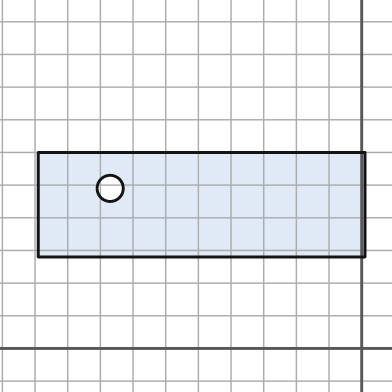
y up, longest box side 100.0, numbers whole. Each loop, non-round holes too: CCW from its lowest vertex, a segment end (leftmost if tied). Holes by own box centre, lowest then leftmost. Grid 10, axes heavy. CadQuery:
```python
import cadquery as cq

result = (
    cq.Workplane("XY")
    .moveTo(-99.0, 28.0)
    .lineTo(1.0, 28.0)
    .lineTo(1.0, 60.0)
    .lineTo(-99.0, 60.0)
    .close()
    .moveTo(-77.0, 49.0)
    .circle(4.0)
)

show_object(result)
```